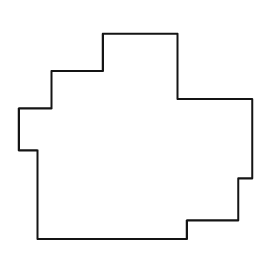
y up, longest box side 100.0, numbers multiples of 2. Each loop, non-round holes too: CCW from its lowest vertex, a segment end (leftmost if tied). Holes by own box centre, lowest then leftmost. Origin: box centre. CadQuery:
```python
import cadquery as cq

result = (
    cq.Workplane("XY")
    .moveTo(-42.0, -44.0)
    .lineTo(22.0, -44.0)
    .lineTo(22.0, -36.0)
    .lineTo(44.0, -36.0)
    .lineTo(44.0, -18.0)
    .lineTo(50.0, -18.0)
    .lineTo(50.0, 16.0)
    .lineTo(18.0, 16.0)
    .lineTo(18.0, 44.0)
    .lineTo(-14.0, 44.0)
    .lineTo(-14.0, 28.0)
    .lineTo(-36.0, 28.0)
    .lineTo(-36.0, 12.0)
    .lineTo(-50.0, 12.0)
    .lineTo(-50.0, -6.0)
    .lineTo(-42.0, -6.0)
    .close()
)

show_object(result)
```